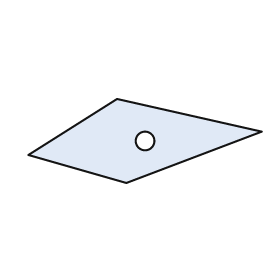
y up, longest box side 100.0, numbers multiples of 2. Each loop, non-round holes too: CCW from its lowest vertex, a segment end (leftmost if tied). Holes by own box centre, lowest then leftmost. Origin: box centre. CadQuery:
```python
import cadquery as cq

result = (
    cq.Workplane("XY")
    .moveTo(-8.0, -18.0)
    .lineTo(50.0, 4.0)
    .lineTo(-12.0, 18.0)
    .lineTo(-50.0, -6.0)
    .close()
    .moveTo(0.0, 0.0)
    .circle(4.0)
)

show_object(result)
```